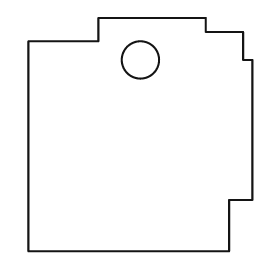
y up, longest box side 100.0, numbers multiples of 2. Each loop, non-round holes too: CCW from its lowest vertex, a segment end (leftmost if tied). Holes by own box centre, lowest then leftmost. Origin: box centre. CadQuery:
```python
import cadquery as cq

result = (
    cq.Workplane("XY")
    .moveTo(-48.0, -50.0)
    .lineTo(38.0, -50.0)
    .lineTo(38.0, -28.0)
    .lineTo(48.0, -28.0)
    .lineTo(48.0, 32.0)
    .lineTo(44.0, 32.0)
    .lineTo(44.0, 44.0)
    .lineTo(28.0, 44.0)
    .lineTo(28.0, 50.0)
    .lineTo(-18.0, 50.0)
    .lineTo(-18.0, 40.0)
    .lineTo(-48.0, 40.0)
    .close()
    .moveTo(0.0, 32.0)
    .circle(8.0)
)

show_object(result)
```